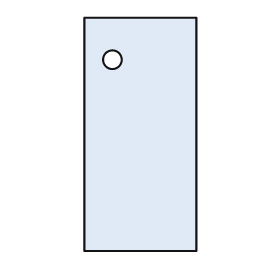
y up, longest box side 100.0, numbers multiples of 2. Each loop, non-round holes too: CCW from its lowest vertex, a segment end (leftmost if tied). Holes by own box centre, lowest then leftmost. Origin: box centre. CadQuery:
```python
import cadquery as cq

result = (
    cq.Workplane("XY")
    .moveTo(-24.0, -50.0)
    .lineTo(24.0, -50.0)
    .lineTo(24.0, 50.0)
    .lineTo(-24.0, 50.0)
    .close()
    .moveTo(-12.0, 32.0)
    .circle(4.0)
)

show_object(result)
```